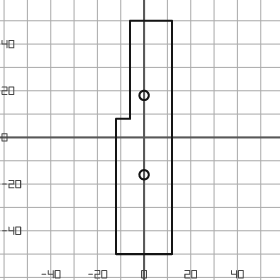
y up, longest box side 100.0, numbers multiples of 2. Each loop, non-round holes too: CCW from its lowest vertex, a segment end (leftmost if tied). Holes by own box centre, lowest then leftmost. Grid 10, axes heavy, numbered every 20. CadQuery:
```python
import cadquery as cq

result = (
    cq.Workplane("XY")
    .moveTo(-12.0, -50.0)
    .lineTo(12.0, -50.0)
    .lineTo(12.0, 50.0)
    .lineTo(-6.0, 50.0)
    .lineTo(-6.0, 8.0)
    .lineTo(-12.0, 8.0)
    .close()
    .moveTo(0.0, -16.0)
    .circle(2.0)
    .moveTo(0.0, 18.0)
    .circle(2.0)
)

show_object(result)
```